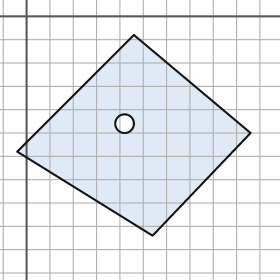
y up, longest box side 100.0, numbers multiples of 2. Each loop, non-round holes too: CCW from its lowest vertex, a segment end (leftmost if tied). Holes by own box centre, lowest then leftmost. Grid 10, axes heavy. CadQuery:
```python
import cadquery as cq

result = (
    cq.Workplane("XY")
    .moveTo(54.0, -94.0)
    .lineTo(96.0, -50.0)
    .lineTo(46.0, -8.0)
    .lineTo(-4.0, -58.0)
    .close()
    .moveTo(42.0, -46.0)
    .circle(4.0)
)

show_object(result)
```